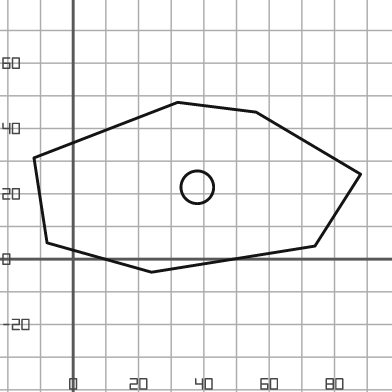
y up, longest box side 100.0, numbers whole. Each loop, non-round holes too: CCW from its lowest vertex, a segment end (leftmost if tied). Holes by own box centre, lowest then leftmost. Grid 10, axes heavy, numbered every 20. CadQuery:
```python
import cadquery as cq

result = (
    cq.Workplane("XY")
    .moveTo(24.0, -4.0)
    .lineTo(74.0, 4.0)
    .lineTo(88.0, 26.0)
    .lineTo(56.0, 45.0)
    .lineTo(32.0, 48.0)
    .lineTo(-12.0, 31.0)
    .lineTo(-8.0, 5.0)
    .close()
    .moveTo(38.0, 22.0)
    .circle(5.0)
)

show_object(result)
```